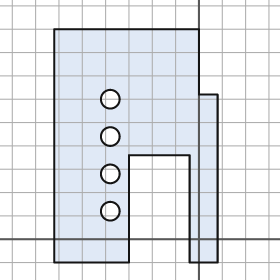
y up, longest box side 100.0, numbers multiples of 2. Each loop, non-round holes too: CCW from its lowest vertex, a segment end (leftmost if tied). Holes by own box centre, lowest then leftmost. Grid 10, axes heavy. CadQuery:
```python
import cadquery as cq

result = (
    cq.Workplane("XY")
    .moveTo(-62.0, -10.0)
    .lineTo(-30.0, -10.0)
    .lineTo(-30.0, 36.0)
    .lineTo(-4.0, 36.0)
    .lineTo(-4.0, -10.0)
    .lineTo(8.0, -10.0)
    .lineTo(8.0, 62.0)
    .lineTo(0.0, 62.0)
    .lineTo(0.0, 90.0)
    .lineTo(-62.0, 90.0)
    .close()
    .moveTo(-38.0, 12.0)
    .circle(4.0)
    .moveTo(-38.0, 28.0)
    .circle(4.0)
    .moveTo(-38.0, 44.0)
    .circle(4.0)
    .moveTo(-38.0, 60.0)
    .circle(4.0)
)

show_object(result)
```